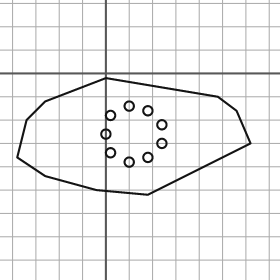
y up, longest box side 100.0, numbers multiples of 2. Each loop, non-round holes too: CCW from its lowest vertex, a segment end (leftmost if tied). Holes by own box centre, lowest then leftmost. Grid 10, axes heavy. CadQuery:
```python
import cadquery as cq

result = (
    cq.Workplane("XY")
    .moveTo(18.0, -52.0)
    .lineTo(62.0, -30.0)
    .lineTo(56.0, -16.0)
    .lineTo(48.0, -10.0)
    .lineTo(0.0, -2.0)
    .lineTo(-26.0, -12.0)
    .lineTo(-34.0, -20.0)
    .lineTo(-38.0, -36.0)
    .lineTo(-26.0, -44.0)
    .lineTo(-4.0, -50.0)
    .close()
    .moveTo(10.0, -38.0)
    .circle(2.0)
    .moveTo(18.0, -36.0)
    .circle(2.0)
    .moveTo(2.0, -34.0)
    .circle(2.0)
    .moveTo(24.0, -30.0)
    .circle(2.0)
    .moveTo(0.0, -26.0)
    .circle(2.0)
    .moveTo(24.0, -22.0)
    .circle(2.0)
    .moveTo(2.0, -18.0)
    .circle(2.0)
    .moveTo(18.0, -16.0)
    .circle(2.0)
    .moveTo(10.0, -14.0)
    .circle(2.0)
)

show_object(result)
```